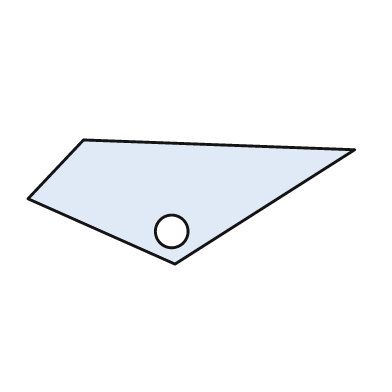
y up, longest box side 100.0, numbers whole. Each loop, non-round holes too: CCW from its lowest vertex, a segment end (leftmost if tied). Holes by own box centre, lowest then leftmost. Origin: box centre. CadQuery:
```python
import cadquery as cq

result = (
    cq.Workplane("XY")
    .moveTo(-5.0, -19.0)
    .lineTo(50.0, 16.0)
    .lineTo(-33.0, 19.0)
    .lineTo(-50.0, 1.0)
    .close()
    .moveTo(-6.0, -9.0)
    .circle(5.0)
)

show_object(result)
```